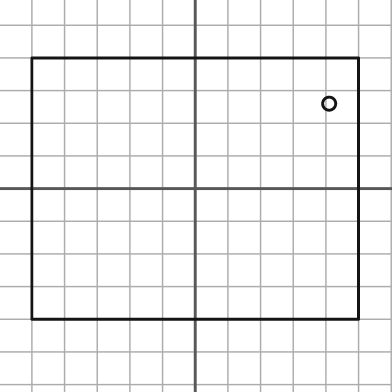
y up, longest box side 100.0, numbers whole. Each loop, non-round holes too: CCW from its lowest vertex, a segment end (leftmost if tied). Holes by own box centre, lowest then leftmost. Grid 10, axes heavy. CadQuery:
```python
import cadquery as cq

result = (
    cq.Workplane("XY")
    .moveTo(-50.0, -40.0)
    .lineTo(50.0, -40.0)
    .lineTo(50.0, 40.0)
    .lineTo(-50.0, 40.0)
    .close()
    .moveTo(41.0, 26.0)
    .circle(2.0)
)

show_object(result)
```